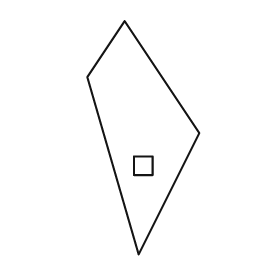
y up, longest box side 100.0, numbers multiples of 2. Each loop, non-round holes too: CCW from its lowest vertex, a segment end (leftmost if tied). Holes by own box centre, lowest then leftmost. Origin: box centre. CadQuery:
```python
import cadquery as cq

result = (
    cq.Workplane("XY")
    .moveTo(-2.0, -50.0)
    .lineTo(24.0, 2.0)
    .lineTo(-8.0, 50.0)
    .lineTo(-24.0, 26.0)
    .close()
    .moveTo(-4.0, -16.0)
    .lineTo(4.0, -16.0)
    .lineTo(4.0, -8.0)
    .lineTo(-4.0, -8.0)
    .close()
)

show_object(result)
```